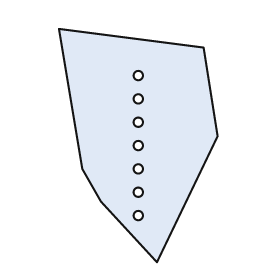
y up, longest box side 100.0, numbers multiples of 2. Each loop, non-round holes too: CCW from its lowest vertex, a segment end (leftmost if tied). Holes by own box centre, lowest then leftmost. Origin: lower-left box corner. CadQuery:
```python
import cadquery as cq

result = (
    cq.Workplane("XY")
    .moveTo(42.0, 0.0)
    .lineTo(68.0, 54.0)
    .lineTo(62.0, 92.0)
    .lineTo(0.0, 100.0)
    .lineTo(10.0, 40.0)
    .lineTo(18.0, 26.0)
    .close()
    .moveTo(34.0, 20.0)
    .circle(2.0)
    .moveTo(34.0, 30.0)
    .circle(2.0)
    .moveTo(34.0, 40.0)
    .circle(2.0)
    .moveTo(34.0, 50.0)
    .circle(2.0)
    .moveTo(34.0, 60.0)
    .circle(2.0)
    .moveTo(34.0, 70.0)
    .circle(2.0)
    .moveTo(34.0, 80.0)
    .circle(2.0)
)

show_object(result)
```